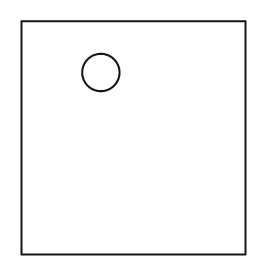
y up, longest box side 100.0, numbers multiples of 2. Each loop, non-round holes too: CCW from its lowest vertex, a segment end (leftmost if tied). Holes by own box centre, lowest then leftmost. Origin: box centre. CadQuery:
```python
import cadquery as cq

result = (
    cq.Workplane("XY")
    .moveTo(-48.0, -50.0)
    .lineTo(48.0, -50.0)
    .lineTo(48.0, 50.0)
    .lineTo(-48.0, 50.0)
    .close()
    .moveTo(-14.0, 28.0)
    .circle(8.0)
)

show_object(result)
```